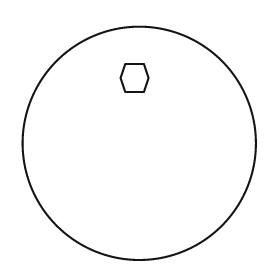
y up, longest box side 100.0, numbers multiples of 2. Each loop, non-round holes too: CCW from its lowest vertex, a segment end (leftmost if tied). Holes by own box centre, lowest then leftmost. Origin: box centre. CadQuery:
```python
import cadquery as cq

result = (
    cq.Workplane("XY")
    .moveTo(0.0, 0.0)
    .circle(50.0)
    .moveTo(-6.0, 22.0)
    .lineTo(2.0, 22.0)
    .lineTo(4.0, 28.0)
    .lineTo(2.0, 34.0)
    .lineTo(-6.0, 34.0)
    .lineTo(-8.0, 28.0)
    .close()
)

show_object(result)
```